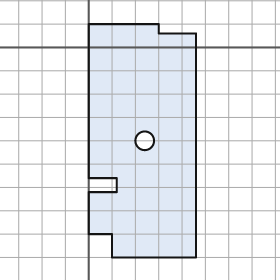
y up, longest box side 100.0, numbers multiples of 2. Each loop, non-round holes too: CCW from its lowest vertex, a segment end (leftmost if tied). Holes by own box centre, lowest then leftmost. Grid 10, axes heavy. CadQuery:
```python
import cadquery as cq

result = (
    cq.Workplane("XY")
    .moveTo(10.0, -90.0)
    .lineTo(46.0, -90.0)
    .lineTo(46.0, 6.0)
    .lineTo(30.0, 6.0)
    .lineTo(30.0, 10.0)
    .lineTo(0.0, 10.0)
    .lineTo(0.0, -56.0)
    .lineTo(12.0, -56.0)
    .lineTo(12.0, -62.0)
    .lineTo(0.0, -62.0)
    .lineTo(0.0, -80.0)
    .lineTo(10.0, -80.0)
    .close()
    .moveTo(24.0, -40.0)
    .circle(4.0)
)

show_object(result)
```